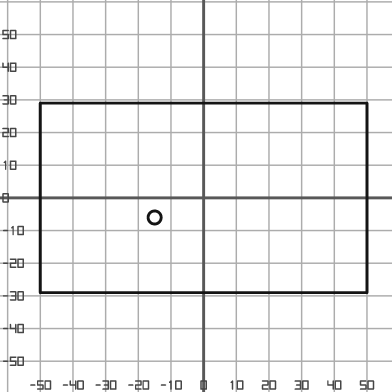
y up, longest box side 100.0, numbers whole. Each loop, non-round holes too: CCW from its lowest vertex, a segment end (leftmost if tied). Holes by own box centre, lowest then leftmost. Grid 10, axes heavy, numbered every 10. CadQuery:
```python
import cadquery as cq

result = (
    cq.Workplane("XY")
    .moveTo(-50.0, -29.0)
    .lineTo(50.0, -29.0)
    .lineTo(50.0, 29.0)
    .lineTo(-50.0, 29.0)
    .close()
    .moveTo(-15.0, -6.0)
    .circle(2.0)
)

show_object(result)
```